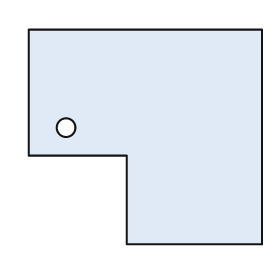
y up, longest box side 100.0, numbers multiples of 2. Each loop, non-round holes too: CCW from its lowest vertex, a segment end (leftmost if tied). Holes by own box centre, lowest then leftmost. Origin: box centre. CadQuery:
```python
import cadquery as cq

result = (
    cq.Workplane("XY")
    .moveTo(-8.0, -46.0)
    .lineTo(50.0, -46.0)
    .lineTo(50.0, 46.0)
    .lineTo(-50.0, 46.0)
    .lineTo(-50.0, -8.0)
    .lineTo(-8.0, -8.0)
    .close()
    .moveTo(-34.0, 4.0)
    .circle(4.0)
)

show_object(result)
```